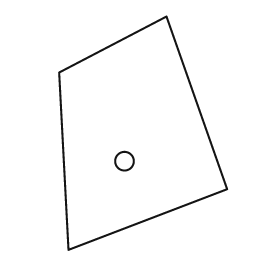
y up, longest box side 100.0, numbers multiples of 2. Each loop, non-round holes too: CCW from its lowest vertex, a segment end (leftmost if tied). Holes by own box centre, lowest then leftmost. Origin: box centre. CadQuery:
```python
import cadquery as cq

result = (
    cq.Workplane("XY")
    .moveTo(-32.0, -50.0)
    .lineTo(36.0, -24.0)
    .lineTo(10.0, 50.0)
    .lineTo(-36.0, 26.0)
    .close()
    .moveTo(-8.0, -12.0)
    .circle(4.0)
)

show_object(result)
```